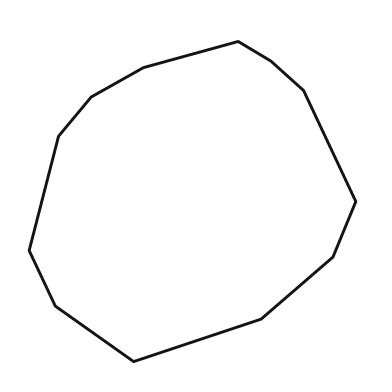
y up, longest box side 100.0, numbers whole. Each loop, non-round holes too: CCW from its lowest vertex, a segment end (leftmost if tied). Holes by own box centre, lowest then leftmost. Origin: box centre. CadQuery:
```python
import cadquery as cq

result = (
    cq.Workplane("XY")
    .moveTo(-18.0, -49.0)
    .lineTo(21.0, -36.0)
    .lineTo(43.0, -17.0)
    .lineTo(50.0, 0.0)
    .lineTo(34.0, 34.0)
    .lineTo(24.0, 43.0)
    .lineTo(14.0, 49.0)
    .lineTo(-15.0, 41.0)
    .lineTo(-31.0, 32.0)
    .lineTo(-41.0, 20.0)
    .lineTo(-50.0, -15.0)
    .lineTo(-42.0, -32.0)
    .close()
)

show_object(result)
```